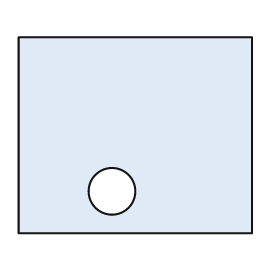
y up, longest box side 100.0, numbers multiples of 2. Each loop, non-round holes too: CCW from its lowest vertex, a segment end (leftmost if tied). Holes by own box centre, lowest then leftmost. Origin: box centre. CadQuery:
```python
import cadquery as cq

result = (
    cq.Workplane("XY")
    .moveTo(-50.0, -42.0)
    .lineTo(50.0, -42.0)
    .lineTo(50.0, 42.0)
    .lineTo(-50.0, 42.0)
    .close()
    .moveTo(-10.0, -24.0)
    .circle(10.0)
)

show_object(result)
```